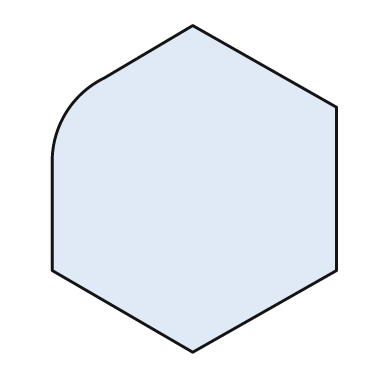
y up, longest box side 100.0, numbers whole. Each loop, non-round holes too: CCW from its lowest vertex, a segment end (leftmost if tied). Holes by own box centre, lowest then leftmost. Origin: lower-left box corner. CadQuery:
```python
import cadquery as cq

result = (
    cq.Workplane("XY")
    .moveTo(43.0, 0.0)
    .lineTo(87.0, 25.0)
    .lineTo(87.0, 75.0)
    .lineTo(43.0, 100.0)
    .lineTo(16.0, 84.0)
    .threePointArc((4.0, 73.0), (0.0, 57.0))
    .lineTo(0.0, 25.0)
    .close()
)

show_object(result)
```